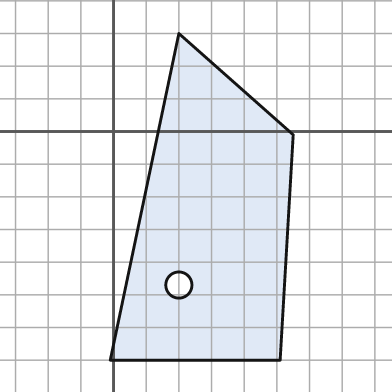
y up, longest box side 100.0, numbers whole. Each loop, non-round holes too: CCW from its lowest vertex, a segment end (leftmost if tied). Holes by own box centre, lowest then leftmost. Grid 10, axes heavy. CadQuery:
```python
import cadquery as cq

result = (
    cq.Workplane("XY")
    .moveTo(-1.0, -70.0)
    .lineTo(51.0, -70.0)
    .lineTo(55.0, -1.0)
    .lineTo(20.0, 30.0)
    .close()
    .moveTo(20.0, -47.0)
    .circle(4.0)
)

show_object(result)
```